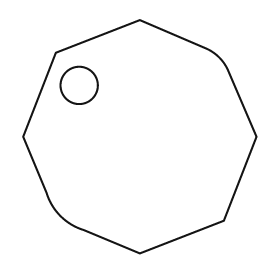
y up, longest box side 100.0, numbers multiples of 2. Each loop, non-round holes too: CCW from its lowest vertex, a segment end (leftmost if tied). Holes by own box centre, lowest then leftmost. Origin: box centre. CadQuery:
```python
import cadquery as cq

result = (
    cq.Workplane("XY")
    .moveTo(0.0, -50.0)
    .lineTo(36.0, -36.0)
    .lineTo(50.0, 0.0)
    .lineTo(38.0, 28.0)
    .threePointArc((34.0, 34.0), (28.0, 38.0))
    .lineTo(0.0, 50.0)
    .lineTo(-36.0, 36.0)
    .lineTo(-50.0, 0.0)
    .lineTo(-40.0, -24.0)
    .threePointArc((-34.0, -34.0), (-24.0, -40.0))
    .close()
    .moveTo(-26.0, 22.0)
    .circle(8.0)
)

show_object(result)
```